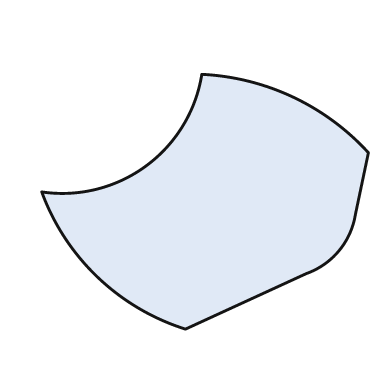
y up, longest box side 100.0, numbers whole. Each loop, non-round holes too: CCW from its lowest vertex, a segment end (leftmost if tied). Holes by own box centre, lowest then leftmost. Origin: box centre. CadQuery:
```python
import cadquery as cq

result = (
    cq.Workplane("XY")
    .moveTo(-6.0, -39.0)
    .lineTo(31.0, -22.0)
    .threePointArc((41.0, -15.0), (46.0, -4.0))
    .lineTo(50.0, 15.0)
    .threePointArc((27.0, 32.0), (-1.0, 39.0))
    .threePointArc((-18.0, 11.0), (-50.0, 3.0))
    .threePointArc((-33.0, -23.0), (-6.0, -39.0))
    .close()
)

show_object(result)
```